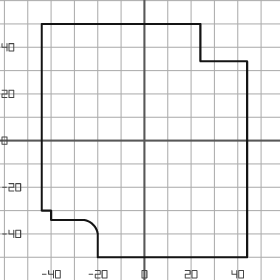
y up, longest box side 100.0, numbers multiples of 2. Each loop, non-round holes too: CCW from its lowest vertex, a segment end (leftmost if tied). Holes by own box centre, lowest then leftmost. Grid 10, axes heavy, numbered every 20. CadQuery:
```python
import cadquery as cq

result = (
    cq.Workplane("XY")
    .moveTo(-20.0, -50.0)
    .lineTo(44.0, -50.0)
    .lineTo(44.0, 34.0)
    .lineTo(24.0, 34.0)
    .lineTo(24.0, 50.0)
    .lineTo(-44.0, 50.0)
    .lineTo(-44.0, -30.0)
    .lineTo(-40.0, -30.0)
    .lineTo(-40.0, -34.0)
    .lineTo(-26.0, -34.0)
    .threePointArc((-22.0, -36.0), (-20.0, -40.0))
    .close()
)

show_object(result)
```